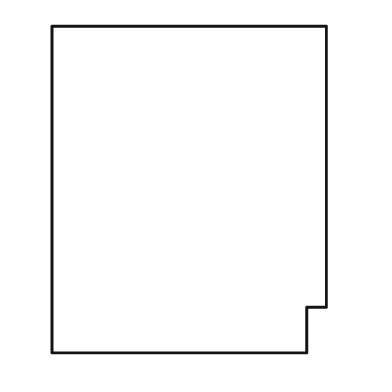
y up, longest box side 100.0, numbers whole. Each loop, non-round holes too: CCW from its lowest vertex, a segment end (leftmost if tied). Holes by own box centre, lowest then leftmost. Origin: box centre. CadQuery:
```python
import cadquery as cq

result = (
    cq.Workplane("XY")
    .moveTo(-42.0, -50.0)
    .lineTo(36.0, -50.0)
    .lineTo(36.0, -36.0)
    .lineTo(42.0, -36.0)
    .lineTo(42.0, 50.0)
    .lineTo(-42.0, 50.0)
    .close()
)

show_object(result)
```